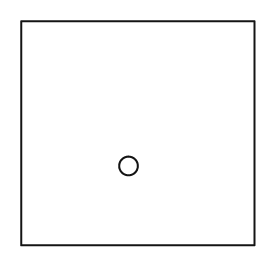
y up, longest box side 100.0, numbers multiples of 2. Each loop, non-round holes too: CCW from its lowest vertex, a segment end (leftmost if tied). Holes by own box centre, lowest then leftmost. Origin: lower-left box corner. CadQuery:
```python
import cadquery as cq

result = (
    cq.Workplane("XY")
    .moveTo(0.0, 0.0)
    .lineTo(100.0, 0.0)
    .lineTo(100.0, 96.0)
    .lineTo(0.0, 96.0)
    .close()
    .moveTo(46.0, 34.0)
    .circle(4.0)
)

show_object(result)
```